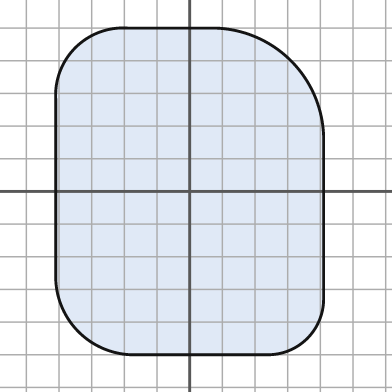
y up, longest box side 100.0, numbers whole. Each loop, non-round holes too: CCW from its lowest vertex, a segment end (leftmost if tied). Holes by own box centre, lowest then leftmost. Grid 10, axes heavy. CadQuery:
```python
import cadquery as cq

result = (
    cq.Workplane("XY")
    .moveTo(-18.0, -50.0)
    .lineTo(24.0, -50.0)
    .threePointArc((36.0, -45.0), (41.0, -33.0))
    .lineTo(41.0, 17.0)
    .threePointArc((31.0, 40.0), (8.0, 50.0))
    .lineTo(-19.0, 50.0)
    .threePointArc((-35.0, 44.0), (-41.0, 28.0))
    .lineTo(-41.0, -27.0)
    .threePointArc((-34.0, -43.0), (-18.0, -50.0))
    .close()
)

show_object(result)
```